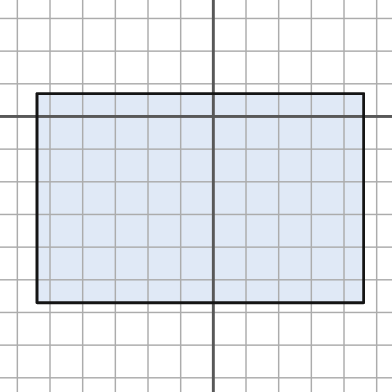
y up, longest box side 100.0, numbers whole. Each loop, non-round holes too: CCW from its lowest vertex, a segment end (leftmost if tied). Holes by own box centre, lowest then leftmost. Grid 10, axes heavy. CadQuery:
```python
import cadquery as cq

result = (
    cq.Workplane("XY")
    .moveTo(-54.0, -57.0)
    .lineTo(46.0, -57.0)
    .lineTo(46.0, 7.0)
    .lineTo(-54.0, 7.0)
    .close()
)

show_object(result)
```